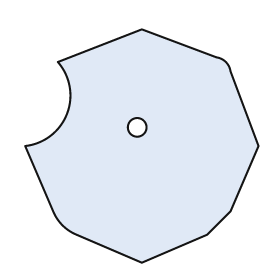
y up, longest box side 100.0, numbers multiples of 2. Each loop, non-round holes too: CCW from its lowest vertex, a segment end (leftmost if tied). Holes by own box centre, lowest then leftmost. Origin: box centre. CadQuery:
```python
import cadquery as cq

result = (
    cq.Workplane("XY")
    .moveTo(0.0, -50.0)
    .lineTo(28.0, -38.0)
    .lineTo(38.0, -28.0)
    .lineTo(50.0, 0.0)
    .lineTo(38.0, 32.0)
    .threePointArc((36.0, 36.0), (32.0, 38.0))
    .lineTo(0.0, 50.0)
    .lineTo(-36.0, 36.0)
    .threePointArc((-32.0, 14.0), (-50.0, 0.0))
    .lineTo(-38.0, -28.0)
    .threePointArc((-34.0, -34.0), (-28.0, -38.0))
    .close()
    .moveTo(-2.0, 8.0)
    .circle(4.0)
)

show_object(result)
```